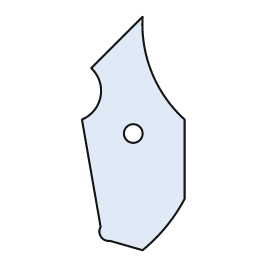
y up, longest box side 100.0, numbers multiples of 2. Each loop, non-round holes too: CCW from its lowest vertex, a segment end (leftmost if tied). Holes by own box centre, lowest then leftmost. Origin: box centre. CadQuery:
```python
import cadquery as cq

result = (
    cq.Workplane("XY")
    .moveTo(4.0, -50.0)
    .threePointArc((14.0, -40.0), (22.0, -28.0))
    .lineTo(22.0, 6.0)
    .threePointArc((8.0, 26.0), (4.0, 50.0))
    .lineTo(-18.0, 28.0)
    .threePointArc((-14.0, 16.0), (-22.0, 6.0))
    .lineTo(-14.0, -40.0)
    .threePointArc((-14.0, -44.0), (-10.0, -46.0))
    .close()
    .moveTo(0.0, 0.0)
    .circle(4.0)
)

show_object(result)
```